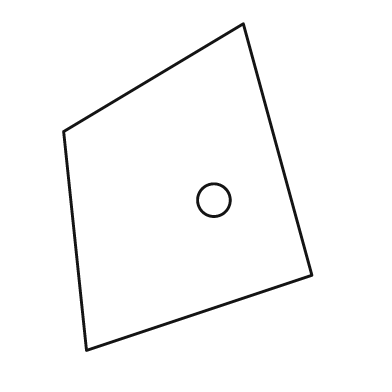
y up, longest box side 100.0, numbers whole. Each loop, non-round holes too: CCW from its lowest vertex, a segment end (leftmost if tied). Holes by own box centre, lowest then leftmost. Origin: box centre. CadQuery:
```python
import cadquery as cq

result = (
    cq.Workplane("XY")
    .moveTo(-31.0, -50.0)
    .lineTo(38.0, -27.0)
    .lineTo(17.0, 50.0)
    .lineTo(-38.0, 17.0)
    .close()
    .moveTo(8.0, -4.0)
    .circle(5.0)
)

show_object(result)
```